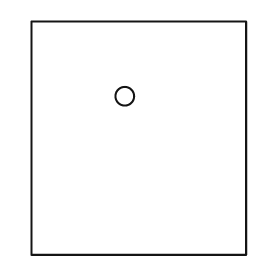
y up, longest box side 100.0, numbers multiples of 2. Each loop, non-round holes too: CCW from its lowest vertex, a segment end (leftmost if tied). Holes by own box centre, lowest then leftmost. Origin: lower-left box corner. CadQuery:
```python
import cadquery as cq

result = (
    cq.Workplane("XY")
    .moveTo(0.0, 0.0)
    .lineTo(92.0, 0.0)
    .lineTo(92.0, 100.0)
    .lineTo(0.0, 100.0)
    .close()
    .moveTo(40.0, 68.0)
    .circle(4.0)
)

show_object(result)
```